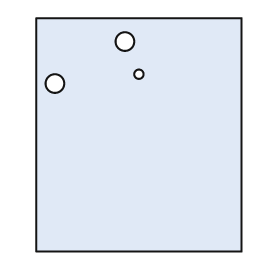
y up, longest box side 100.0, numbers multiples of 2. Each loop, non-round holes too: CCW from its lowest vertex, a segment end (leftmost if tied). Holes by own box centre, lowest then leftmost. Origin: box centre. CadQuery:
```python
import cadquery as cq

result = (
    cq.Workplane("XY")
    .moveTo(-44.0, -50.0)
    .lineTo(44.0, -50.0)
    .lineTo(44.0, 50.0)
    .lineTo(-44.0, 50.0)
    .close()
    .moveTo(-36.0, 22.0)
    .circle(4.0)
    .moveTo(0.0, 26.0)
    .circle(2.0)
    .moveTo(-6.0, 40.0)
    .circle(4.0)
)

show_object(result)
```